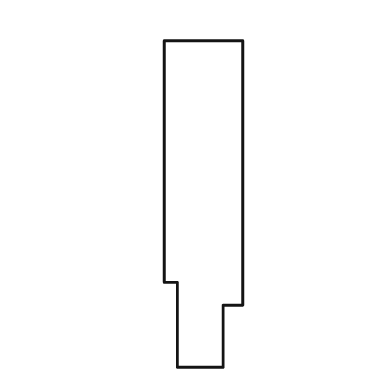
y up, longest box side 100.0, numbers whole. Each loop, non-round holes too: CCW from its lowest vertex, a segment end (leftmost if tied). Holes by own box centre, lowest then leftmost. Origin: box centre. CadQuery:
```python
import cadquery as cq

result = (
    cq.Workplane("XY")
    .moveTo(-8.0, -50.0)
    .lineTo(6.0, -50.0)
    .lineTo(6.0, -31.0)
    .lineTo(12.0, -31.0)
    .lineTo(12.0, 50.0)
    .lineTo(-12.0, 50.0)
    .lineTo(-12.0, -24.0)
    .lineTo(-8.0, -24.0)
    .close()
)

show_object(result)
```